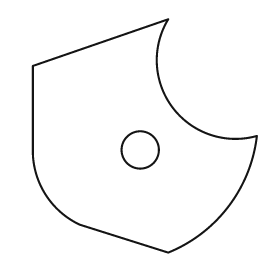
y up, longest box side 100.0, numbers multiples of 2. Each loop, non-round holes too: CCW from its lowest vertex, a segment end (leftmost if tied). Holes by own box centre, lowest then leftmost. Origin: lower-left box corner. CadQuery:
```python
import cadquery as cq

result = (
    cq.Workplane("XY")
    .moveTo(58.0, 0.0)
    .threePointArc((84.0, 20.0), (96.0, 50.0))
    .threePointArc((60.0, 62.0), (58.0, 100.0))
    .lineTo(0.0, 80.0)
    .lineTo(0.0, 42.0)
    .threePointArc((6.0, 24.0), (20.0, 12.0))
    .close()
    .moveTo(46.0, 44.0)
    .circle(8.0)
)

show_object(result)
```